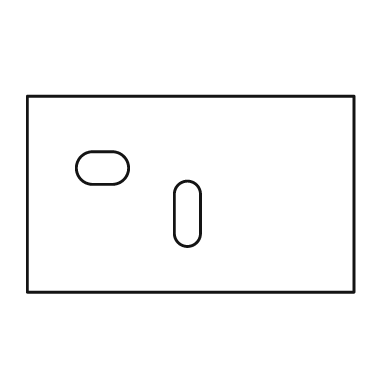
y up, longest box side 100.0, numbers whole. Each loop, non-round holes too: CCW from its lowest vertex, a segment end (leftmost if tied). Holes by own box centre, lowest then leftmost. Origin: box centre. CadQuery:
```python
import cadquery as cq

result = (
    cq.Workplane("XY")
    .moveTo(-50.0, -30.0)
    .lineTo(50.0, -30.0)
    .lineTo(50.0, 30.0)
    .lineTo(-50.0, 30.0)
    .close()
    .moveTo(-5.0, -12.0)
    .threePointArc((-1.0, -16.0), (3.0, -12.0))
    .lineTo(3.0, 0.0)
    .threePointArc((-1.0, 4.0), (-5.0, 0.0))
    .close()
    .moveTo(-30.0, 3.0)
    .lineTo(-24.0, 3.0)
    .threePointArc((-19.0, 8.0), (-24.0, 13.0))
    .lineTo(-30.0, 13.0)
    .threePointArc((-35.0, 8.0), (-30.0, 3.0))
    .close()
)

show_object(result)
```